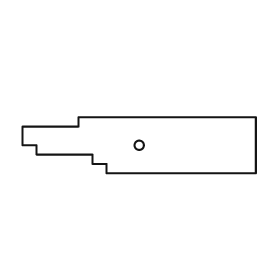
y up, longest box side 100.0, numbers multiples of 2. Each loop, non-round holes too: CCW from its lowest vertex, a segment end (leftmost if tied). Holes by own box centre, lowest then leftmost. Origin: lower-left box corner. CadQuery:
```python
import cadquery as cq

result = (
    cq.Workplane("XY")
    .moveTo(36.0, 0.0)
    .lineTo(100.0, 0.0)
    .lineTo(100.0, 24.0)
    .lineTo(24.0, 24.0)
    .lineTo(24.0, 20.0)
    .lineTo(0.0, 20.0)
    .lineTo(0.0, 12.0)
    .lineTo(6.0, 12.0)
    .lineTo(6.0, 8.0)
    .lineTo(30.0, 8.0)
    .lineTo(30.0, 4.0)
    .lineTo(36.0, 4.0)
    .close()
    .moveTo(50.0, 12.0)
    .circle(2.0)
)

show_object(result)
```